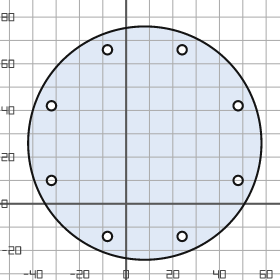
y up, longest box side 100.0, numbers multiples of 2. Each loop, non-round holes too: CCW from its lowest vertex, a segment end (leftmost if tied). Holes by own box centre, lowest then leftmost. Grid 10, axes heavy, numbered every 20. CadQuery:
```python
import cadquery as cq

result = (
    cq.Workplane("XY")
    .moveTo(8.0, 26.0)
    .circle(50.0)
    .moveTo(-8.0, -14.0)
    .circle(2.0)
    .moveTo(24.0, -14.0)
    .circle(2.0)
    .moveTo(-32.0, 10.0)
    .circle(2.0)
    .moveTo(48.0, 10.0)
    .circle(2.0)
    .moveTo(-32.0, 42.0)
    .circle(2.0)
    .moveTo(48.0, 42.0)
    .circle(2.0)
    .moveTo(-8.0, 66.0)
    .circle(2.0)
    .moveTo(24.0, 66.0)
    .circle(2.0)
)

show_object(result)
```